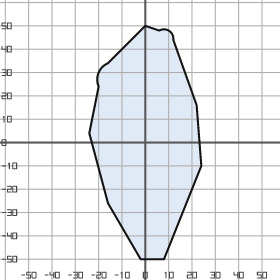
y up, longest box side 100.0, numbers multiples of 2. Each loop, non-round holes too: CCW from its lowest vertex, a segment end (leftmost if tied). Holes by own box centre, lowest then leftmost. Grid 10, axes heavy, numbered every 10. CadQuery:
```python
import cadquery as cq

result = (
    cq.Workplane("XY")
    .moveTo(-2.0, -50.0)
    .lineTo(8.0, -50.0)
    .lineTo(24.0, -10.0)
    .lineTo(22.0, 16.0)
    .lineTo(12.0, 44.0)
    .threePointArc((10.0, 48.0), (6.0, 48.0))
    .lineTo(0.0, 50.0)
    .lineTo(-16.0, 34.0)
    .threePointArc((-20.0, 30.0), (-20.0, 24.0))
    .lineTo(-24.0, 4.0)
    .lineTo(-16.0, -26.0)
    .close()
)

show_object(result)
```